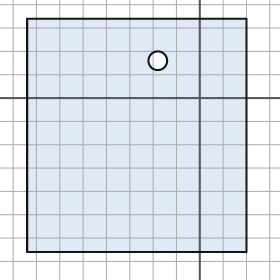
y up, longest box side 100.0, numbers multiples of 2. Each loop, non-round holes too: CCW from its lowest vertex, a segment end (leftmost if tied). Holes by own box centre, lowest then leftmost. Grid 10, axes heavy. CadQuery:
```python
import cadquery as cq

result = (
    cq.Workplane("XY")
    .moveTo(-74.0, -66.0)
    .lineTo(20.0, -66.0)
    .lineTo(20.0, 34.0)
    .lineTo(-74.0, 34.0)
    .close()
    .moveTo(-18.0, 16.0)
    .circle(4.0)
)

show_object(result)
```